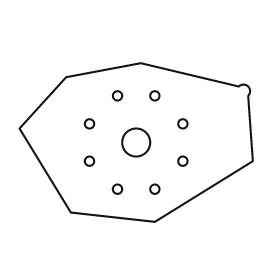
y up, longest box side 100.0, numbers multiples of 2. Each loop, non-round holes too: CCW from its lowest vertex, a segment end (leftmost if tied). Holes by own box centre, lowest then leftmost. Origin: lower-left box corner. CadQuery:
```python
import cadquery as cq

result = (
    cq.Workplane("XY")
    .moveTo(58.0, 0.0)
    .lineTo(100.0, 26.0)
    .lineTo(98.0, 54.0)
    .threePointArc((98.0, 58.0), (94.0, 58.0))
    .lineTo(52.0, 68.0)
    .lineTo(20.0, 62.0)
    .lineTo(0.0, 40.0)
    .lineTo(22.0, 4.0)
    .close()
    .moveTo(42.0, 14.0)
    .circle(2.0)
    .moveTo(58.0, 14.0)
    .circle(2.0)
    .moveTo(30.0, 26.0)
    .circle(2.0)
    .moveTo(70.0, 26.0)
    .circle(2.0)
    .moveTo(50.0, 34.0)
    .circle(6.0)
    .moveTo(30.0, 42.0)
    .circle(2.0)
    .moveTo(70.0, 42.0)
    .circle(2.0)
    .moveTo(42.0, 54.0)
    .circle(2.0)
    .moveTo(58.0, 54.0)
    .circle(2.0)
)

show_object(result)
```